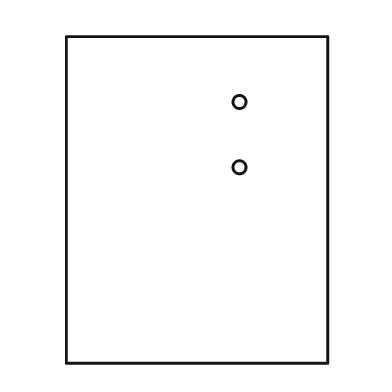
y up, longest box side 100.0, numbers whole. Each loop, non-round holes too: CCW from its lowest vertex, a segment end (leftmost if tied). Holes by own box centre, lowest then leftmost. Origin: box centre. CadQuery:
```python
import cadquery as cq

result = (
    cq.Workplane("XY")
    .moveTo(-40.0, -50.0)
    .lineTo(40.0, -50.0)
    .lineTo(40.0, 50.0)
    .lineTo(-40.0, 50.0)
    .close()
    .moveTo(13.0, 10.0)
    .circle(2.0)
    .moveTo(13.0, 30.0)
    .circle(2.0)
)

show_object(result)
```